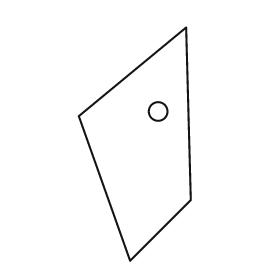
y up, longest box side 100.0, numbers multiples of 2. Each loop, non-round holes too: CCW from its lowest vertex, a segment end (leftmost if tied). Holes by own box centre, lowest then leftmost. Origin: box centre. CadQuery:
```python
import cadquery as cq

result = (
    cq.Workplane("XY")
    .moveTo(-2.0, -50.0)
    .lineTo(24.0, -24.0)
    .lineTo(22.0, 50.0)
    .lineTo(-24.0, 12.0)
    .close()
    .moveTo(10.0, 14.0)
    .circle(4.0)
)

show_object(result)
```